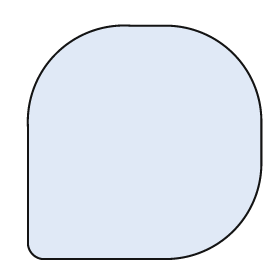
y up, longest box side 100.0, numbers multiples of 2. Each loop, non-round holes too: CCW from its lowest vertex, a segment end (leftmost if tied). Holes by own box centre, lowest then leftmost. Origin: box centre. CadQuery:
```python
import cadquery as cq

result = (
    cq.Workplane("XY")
    .moveTo(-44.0, -50.0)
    .lineTo(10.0, -50.0)
    .threePointArc((38.0, -38.0), (50.0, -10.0))
    .lineTo(50.0, 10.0)
    .threePointArc((38.0, 38.0), (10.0, 50.0))
    .lineTo(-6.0, 50.0)
    .threePointArc((-38.0, 38.0), (-50.0, 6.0))
    .lineTo(-50.0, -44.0)
    .threePointArc((-48.0, -48.0), (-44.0, -50.0))
    .close()
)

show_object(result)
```